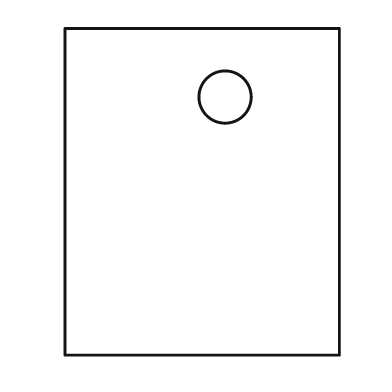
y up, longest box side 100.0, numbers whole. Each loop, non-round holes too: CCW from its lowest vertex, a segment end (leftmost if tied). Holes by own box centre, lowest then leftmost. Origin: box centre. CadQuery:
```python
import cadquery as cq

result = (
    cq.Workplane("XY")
    .moveTo(-42.0, -50.0)
    .lineTo(42.0, -50.0)
    .lineTo(42.0, 50.0)
    .lineTo(-42.0, 50.0)
    .close()
    .moveTo(7.0, 29.0)
    .circle(8.0)
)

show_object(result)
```